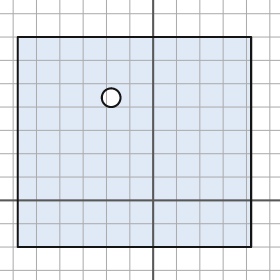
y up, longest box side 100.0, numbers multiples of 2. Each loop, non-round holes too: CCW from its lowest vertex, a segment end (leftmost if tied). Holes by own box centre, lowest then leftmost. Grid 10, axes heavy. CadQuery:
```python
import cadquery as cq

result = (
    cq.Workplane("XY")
    .moveTo(-58.0, -20.0)
    .lineTo(42.0, -20.0)
    .lineTo(42.0, 70.0)
    .lineTo(-58.0, 70.0)
    .close()
    .moveTo(-18.0, 44.0)
    .circle(4.0)
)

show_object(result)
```